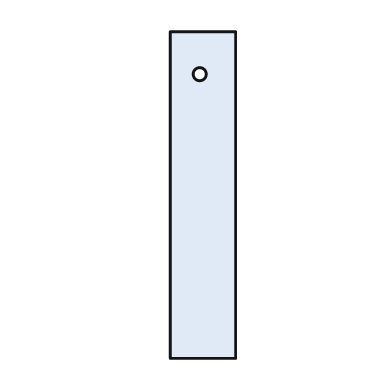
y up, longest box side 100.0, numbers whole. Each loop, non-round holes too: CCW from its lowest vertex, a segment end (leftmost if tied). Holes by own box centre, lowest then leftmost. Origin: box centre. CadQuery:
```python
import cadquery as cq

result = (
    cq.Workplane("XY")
    .moveTo(-10.0, -50.0)
    .lineTo(10.0, -50.0)
    .lineTo(10.0, 50.0)
    .lineTo(-10.0, 50.0)
    .close()
    .moveTo(-1.0, 37.0)
    .circle(2.0)
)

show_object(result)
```